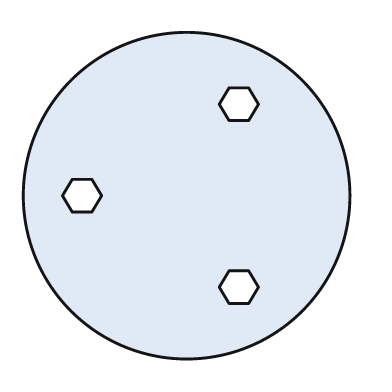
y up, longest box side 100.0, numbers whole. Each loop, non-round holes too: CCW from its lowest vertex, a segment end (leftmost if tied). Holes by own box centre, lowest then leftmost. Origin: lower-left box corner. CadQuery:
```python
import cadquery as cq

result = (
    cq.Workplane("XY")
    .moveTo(50.0, 50.0)
    .circle(50.0)
    .moveTo(63.0, 17.0)
    .lineTo(69.0, 17.0)
    .lineTo(72.0, 22.0)
    .lineTo(69.0, 27.0)
    .lineTo(63.0, 27.0)
    .lineTo(60.0, 22.0)
    .close()
    .moveTo(15.0, 45.0)
    .lineTo(21.0, 45.0)
    .lineTo(24.0, 50.0)
    .lineTo(21.0, 55.0)
    .lineTo(15.0, 55.0)
    .lineTo(12.0, 50.0)
    .close()
    .moveTo(63.0, 73.0)
    .lineTo(69.0, 73.0)
    .lineTo(72.0, 78.0)
    .lineTo(69.0, 83.0)
    .lineTo(63.0, 83.0)
    .lineTo(60.0, 78.0)
    .close()
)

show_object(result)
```